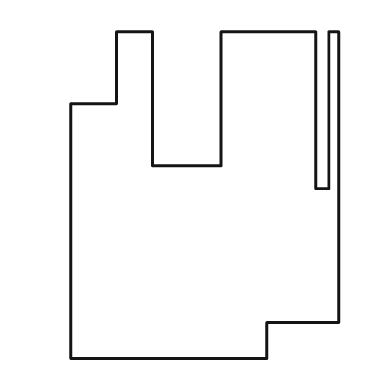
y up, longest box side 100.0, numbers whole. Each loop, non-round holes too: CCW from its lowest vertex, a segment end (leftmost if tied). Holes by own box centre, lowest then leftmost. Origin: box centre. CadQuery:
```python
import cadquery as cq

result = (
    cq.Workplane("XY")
    .moveTo(-41.0, -50.0)
    .lineTo(19.0, -50.0)
    .lineTo(19.0, -39.0)
    .lineTo(41.0, -39.0)
    .lineTo(41.0, 50.0)
    .lineTo(38.0, 50.0)
    .lineTo(38.0, 2.0)
    .lineTo(34.0, 2.0)
    .lineTo(34.0, 50.0)
    .lineTo(5.0, 50.0)
    .lineTo(5.0, 9.0)
    .lineTo(-16.0, 9.0)
    .lineTo(-16.0, 50.0)
    .lineTo(-27.0, 50.0)
    .lineTo(-27.0, 28.0)
    .lineTo(-41.0, 28.0)
    .close()
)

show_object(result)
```